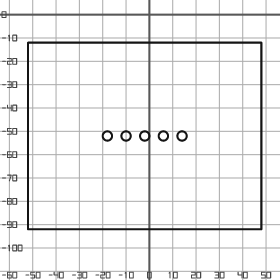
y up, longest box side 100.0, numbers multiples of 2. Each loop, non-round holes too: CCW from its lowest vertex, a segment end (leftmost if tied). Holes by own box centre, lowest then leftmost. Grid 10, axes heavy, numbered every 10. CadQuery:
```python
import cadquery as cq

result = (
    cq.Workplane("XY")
    .moveTo(-52.0, -92.0)
    .lineTo(48.0, -92.0)
    .lineTo(48.0, -12.0)
    .lineTo(-52.0, -12.0)
    .close()
    .moveTo(-18.0, -52.0)
    .circle(2.0)
    .moveTo(-10.0, -52.0)
    .circle(2.0)
    .moveTo(-2.0, -52.0)
    .circle(2.0)
    .moveTo(6.0, -52.0)
    .circle(2.0)
    .moveTo(14.0, -52.0)
    .circle(2.0)
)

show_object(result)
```